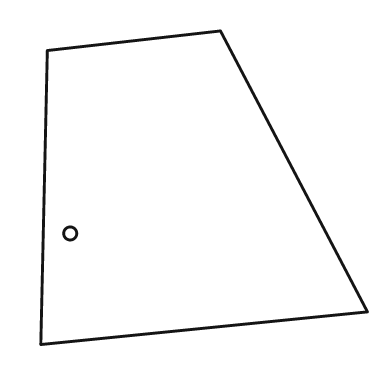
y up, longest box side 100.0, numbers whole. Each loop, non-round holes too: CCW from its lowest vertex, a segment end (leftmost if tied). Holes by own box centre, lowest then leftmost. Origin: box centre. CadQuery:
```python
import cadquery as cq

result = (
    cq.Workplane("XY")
    .moveTo(-50.0, -48.0)
    .lineTo(50.0, -38.0)
    .lineTo(5.0, 48.0)
    .lineTo(-48.0, 42.0)
    .close()
    .moveTo(-41.0, -14.0)
    .circle(2.0)
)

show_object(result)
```